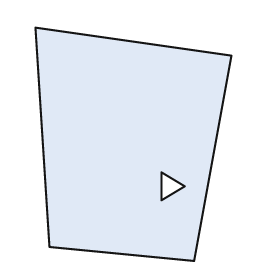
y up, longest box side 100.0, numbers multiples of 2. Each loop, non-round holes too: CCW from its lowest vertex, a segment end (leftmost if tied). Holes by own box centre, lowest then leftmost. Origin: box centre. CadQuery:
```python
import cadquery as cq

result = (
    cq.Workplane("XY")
    .moveTo(26.0, -50.0)
    .lineTo(42.0, 38.0)
    .lineTo(-42.0, 50.0)
    .lineTo(-36.0, -44.0)
    .close()
    .moveTo(12.0, -24.0)
    .lineTo(22.0, -18.0)
    .lineTo(12.0, -12.0)
    .close()
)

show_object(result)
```